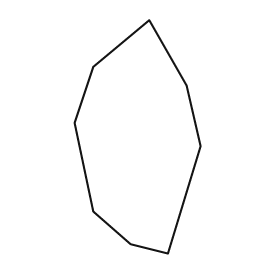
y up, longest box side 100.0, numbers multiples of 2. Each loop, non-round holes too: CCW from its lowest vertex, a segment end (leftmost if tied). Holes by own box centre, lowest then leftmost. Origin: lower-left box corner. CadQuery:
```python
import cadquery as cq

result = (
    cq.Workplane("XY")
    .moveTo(40.0, 0.0)
    .lineTo(54.0, 46.0)
    .lineTo(48.0, 72.0)
    .lineTo(32.0, 100.0)
    .lineTo(8.0, 80.0)
    .lineTo(0.0, 56.0)
    .lineTo(8.0, 18.0)
    .lineTo(24.0, 4.0)
    .close()
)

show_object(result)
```